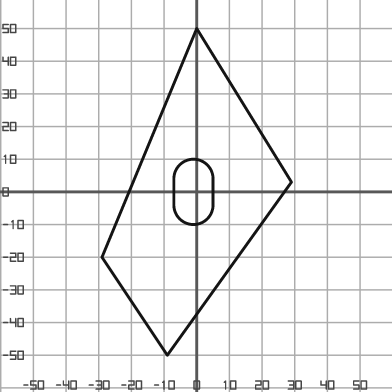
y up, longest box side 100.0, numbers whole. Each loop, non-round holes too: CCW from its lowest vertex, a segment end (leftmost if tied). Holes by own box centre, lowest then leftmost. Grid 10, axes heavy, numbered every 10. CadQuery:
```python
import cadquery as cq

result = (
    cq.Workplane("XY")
    .moveTo(-9.0, -50.0)
    .lineTo(29.0, 3.0)
    .lineTo(0.0, 50.0)
    .lineTo(-29.0, -20.0)
    .close()
    .moveTo(-7.0, -4.0)
    .threePointArc((-1.0, -10.0), (5.0, -4.0))
    .lineTo(5.0, 4.0)
    .threePointArc((-1.0, 10.0), (-7.0, 4.0))
    .close()
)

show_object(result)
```